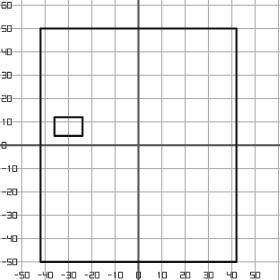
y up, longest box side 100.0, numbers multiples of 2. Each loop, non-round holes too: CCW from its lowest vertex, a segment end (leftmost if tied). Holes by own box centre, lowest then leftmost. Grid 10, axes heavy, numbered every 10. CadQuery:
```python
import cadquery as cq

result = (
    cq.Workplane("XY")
    .moveTo(-42.0, -50.0)
    .lineTo(42.0, -50.0)
    .lineTo(42.0, 50.0)
    .lineTo(-42.0, 50.0)
    .close()
    .moveTo(-36.0, 4.0)
    .lineTo(-24.0, 4.0)
    .lineTo(-24.0, 12.0)
    .lineTo(-36.0, 12.0)
    .close()
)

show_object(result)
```